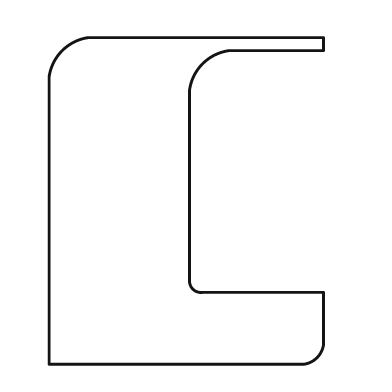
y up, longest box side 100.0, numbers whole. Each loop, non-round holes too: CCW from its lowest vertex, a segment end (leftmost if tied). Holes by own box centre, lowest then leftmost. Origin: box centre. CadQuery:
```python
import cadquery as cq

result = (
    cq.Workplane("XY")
    .moveTo(-42.0, -50.0)
    .lineTo(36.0, -50.0)
    .threePointArc((40.0, -48.0), (42.0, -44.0))
    .lineTo(42.0, -28.0)
    .lineTo(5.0, -28.0)
    .threePointArc((2.0, -27.0), (1.0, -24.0))
    .lineTo(1.0, 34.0)
    .threePointArc((5.0, 42.0), (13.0, 46.0))
    .lineTo(42.0, 46.0)
    .lineTo(42.0, 50.0)
    .lineTo(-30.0, 50.0)
    .threePointArc((-38.0, 46.0), (-42.0, 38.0))
    .close()
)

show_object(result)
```